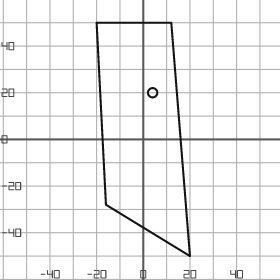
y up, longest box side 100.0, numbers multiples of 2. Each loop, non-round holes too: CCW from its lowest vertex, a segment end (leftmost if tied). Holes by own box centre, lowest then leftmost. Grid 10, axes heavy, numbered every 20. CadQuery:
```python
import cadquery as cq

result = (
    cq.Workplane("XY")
    .moveTo(20.0, -50.0)
    .lineTo(12.0, 50.0)
    .lineTo(-20.0, 50.0)
    .lineTo(-16.0, -28.0)
    .close()
    .moveTo(4.0, 20.0)
    .circle(2.0)
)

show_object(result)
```